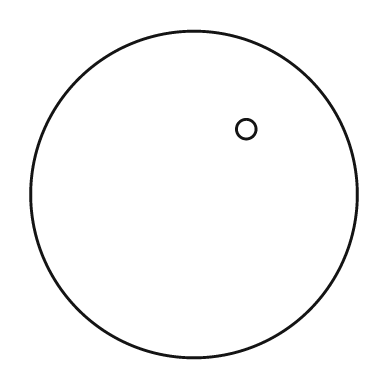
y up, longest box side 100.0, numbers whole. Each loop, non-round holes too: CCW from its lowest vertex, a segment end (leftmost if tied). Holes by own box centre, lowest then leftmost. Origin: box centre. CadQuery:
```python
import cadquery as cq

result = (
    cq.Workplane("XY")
    .moveTo(0.0, 0.0)
    .circle(50.0)
    .moveTo(16.0, 20.0)
    .circle(3.0)
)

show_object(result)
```